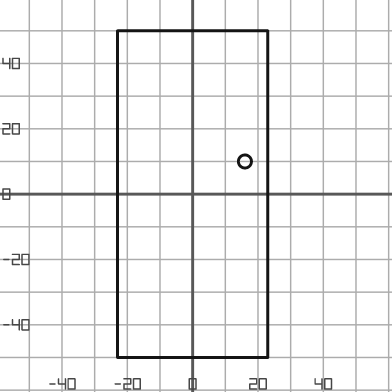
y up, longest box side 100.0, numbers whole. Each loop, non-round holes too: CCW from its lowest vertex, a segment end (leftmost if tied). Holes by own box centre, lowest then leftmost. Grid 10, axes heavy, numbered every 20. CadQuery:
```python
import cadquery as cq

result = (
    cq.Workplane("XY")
    .moveTo(-23.0, -50.0)
    .lineTo(23.0, -50.0)
    .lineTo(23.0, 50.0)
    .lineTo(-23.0, 50.0)
    .close()
    .moveTo(16.0, 10.0)
    .circle(2.0)
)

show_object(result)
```